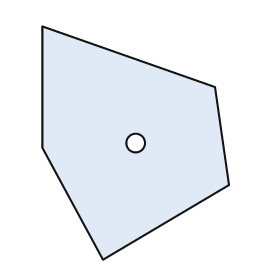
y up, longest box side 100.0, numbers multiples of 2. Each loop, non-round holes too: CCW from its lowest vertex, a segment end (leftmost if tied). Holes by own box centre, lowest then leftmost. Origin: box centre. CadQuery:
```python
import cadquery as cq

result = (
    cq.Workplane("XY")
    .moveTo(-14.0, -50.0)
    .lineTo(40.0, -18.0)
    .lineTo(34.0, 24.0)
    .lineTo(-40.0, 50.0)
    .lineTo(-40.0, -2.0)
    .close()
    .moveTo(0.0, 0.0)
    .circle(4.0)
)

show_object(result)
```